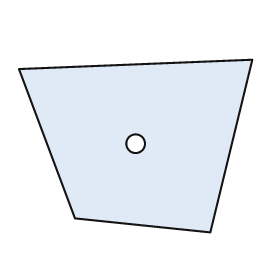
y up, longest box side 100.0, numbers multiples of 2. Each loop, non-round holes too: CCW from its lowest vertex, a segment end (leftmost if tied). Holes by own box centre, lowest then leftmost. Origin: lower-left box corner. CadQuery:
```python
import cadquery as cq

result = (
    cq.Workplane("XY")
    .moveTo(82.0, 0.0)
    .lineTo(100.0, 74.0)
    .lineTo(0.0, 70.0)
    .lineTo(24.0, 6.0)
    .close()
    .moveTo(50.0, 38.0)
    .circle(4.0)
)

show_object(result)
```